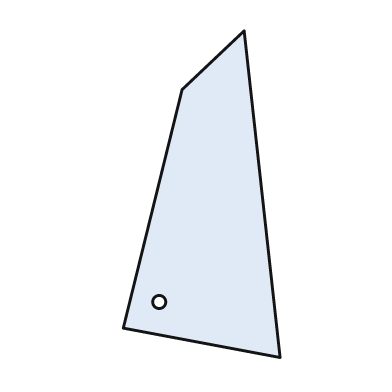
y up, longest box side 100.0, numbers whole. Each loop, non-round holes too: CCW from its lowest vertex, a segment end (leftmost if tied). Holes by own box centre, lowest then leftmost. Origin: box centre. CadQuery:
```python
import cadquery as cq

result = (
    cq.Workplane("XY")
    .moveTo(24.0, -50.0)
    .lineTo(13.0, 50.0)
    .lineTo(-6.0, 32.0)
    .lineTo(-24.0, -41.0)
    .close()
    .moveTo(-13.0, -33.0)
    .circle(2.0)
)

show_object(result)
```